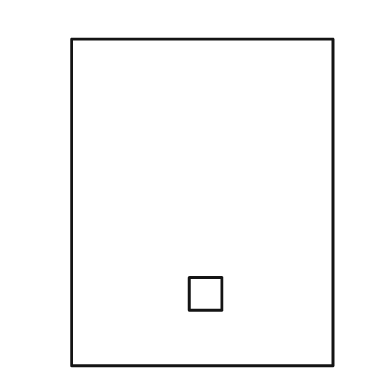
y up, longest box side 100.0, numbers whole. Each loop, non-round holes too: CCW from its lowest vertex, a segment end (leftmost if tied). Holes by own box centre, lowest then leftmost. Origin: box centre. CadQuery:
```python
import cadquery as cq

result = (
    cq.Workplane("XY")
    .moveTo(-40.0, -50.0)
    .lineTo(40.0, -50.0)
    .lineTo(40.0, 50.0)
    .lineTo(-40.0, 50.0)
    .close()
    .moveTo(-4.0, -33.0)
    .lineTo(6.0, -33.0)
    .lineTo(6.0, -23.0)
    .lineTo(-4.0, -23.0)
    .close()
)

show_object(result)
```